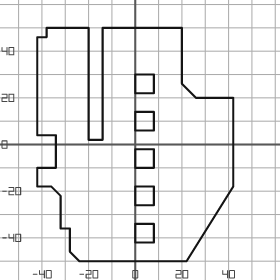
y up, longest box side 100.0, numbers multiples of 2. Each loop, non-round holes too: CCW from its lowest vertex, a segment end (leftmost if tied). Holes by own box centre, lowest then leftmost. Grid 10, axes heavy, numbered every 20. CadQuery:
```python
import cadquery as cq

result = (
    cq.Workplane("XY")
    .moveTo(-24.0, -50.0)
    .lineTo(22.0, -50.0)
    .lineTo(42.0, -18.0)
    .lineTo(42.0, 20.0)
    .lineTo(26.0, 20.0)
    .lineTo(20.0, 26.0)
    .lineTo(20.0, 50.0)
    .lineTo(-14.0, 50.0)
    .lineTo(-14.0, 2.0)
    .lineTo(-20.0, 2.0)
    .lineTo(-20.0, 50.0)
    .lineTo(-38.0, 50.0)
    .lineTo(-38.0, 46.0)
    .lineTo(-42.0, 46.0)
    .lineTo(-42.0, 4.0)
    .lineTo(-34.0, 4.0)
    .lineTo(-34.0, -10.0)
    .lineTo(-42.0, -10.0)
    .lineTo(-42.0, -18.0)
    .lineTo(-36.0, -18.0)
    .lineTo(-32.0, -22.0)
    .lineTo(-32.0, -36.0)
    .lineTo(-28.0, -36.0)
    .lineTo(-28.0, -46.0)
    .close()
    .moveTo(0.0, -42.0)
    .lineTo(8.0, -42.0)
    .lineTo(8.0, -34.0)
    .lineTo(0.0, -34.0)
    .close()
    .moveTo(0.0, -26.0)
    .lineTo(8.0, -26.0)
    .lineTo(8.0, -18.0)
    .lineTo(0.0, -18.0)
    .close()
    .moveTo(0.0, -10.0)
    .lineTo(8.0, -10.0)
    .lineTo(8.0, -2.0)
    .lineTo(0.0, -2.0)
    .close()
    .moveTo(0.0, 6.0)
    .lineTo(8.0, 6.0)
    .lineTo(8.0, 14.0)
    .lineTo(0.0, 14.0)
    .close()
    .moveTo(0.0, 22.0)
    .lineTo(8.0, 22.0)
    .lineTo(8.0, 30.0)
    .lineTo(0.0, 30.0)
    .close()
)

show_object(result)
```